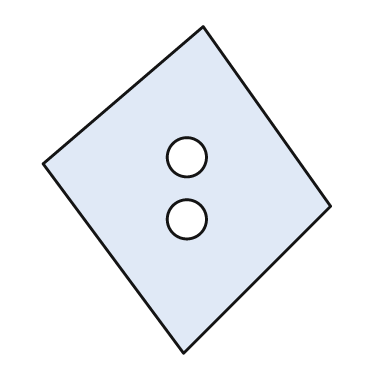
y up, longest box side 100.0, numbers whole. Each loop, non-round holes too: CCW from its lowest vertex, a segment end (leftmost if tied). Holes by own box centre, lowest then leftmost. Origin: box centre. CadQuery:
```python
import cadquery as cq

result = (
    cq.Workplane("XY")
    .moveTo(-1.0, -50.0)
    .lineTo(44.0, -5.0)
    .lineTo(5.0, 50.0)
    .lineTo(-44.0, 8.0)
    .close()
    .moveTo(0.0, -9.0)
    .circle(6.0)
    .moveTo(0.0, 10.0)
    .circle(6.0)
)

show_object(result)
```